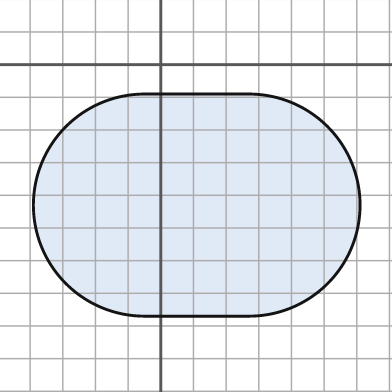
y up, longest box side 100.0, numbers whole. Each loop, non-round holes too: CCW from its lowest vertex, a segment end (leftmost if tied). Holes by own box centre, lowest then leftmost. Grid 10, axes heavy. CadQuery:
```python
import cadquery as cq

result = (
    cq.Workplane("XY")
    .moveTo(-5.0, -77.0)
    .lineTo(27.0, -77.0)
    .threePointArc((61.0, -43.0), (27.0, -9.0))
    .lineTo(-5.0, -9.0)
    .threePointArc((-39.0, -43.0), (-5.0, -77.0))
    .close()
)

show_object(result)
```